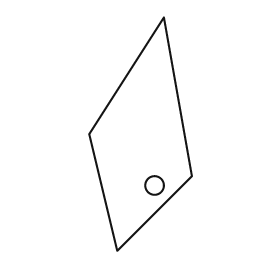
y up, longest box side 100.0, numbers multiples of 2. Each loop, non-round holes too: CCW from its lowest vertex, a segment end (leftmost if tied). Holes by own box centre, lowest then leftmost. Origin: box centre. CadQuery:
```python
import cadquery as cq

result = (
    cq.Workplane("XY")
    .moveTo(-10.0, -50.0)
    .lineTo(22.0, -18.0)
    .lineTo(10.0, 50.0)
    .lineTo(-22.0, 0.0)
    .close()
    .moveTo(6.0, -22.0)
    .circle(4.0)
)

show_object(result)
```